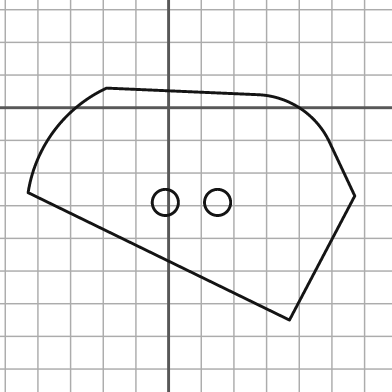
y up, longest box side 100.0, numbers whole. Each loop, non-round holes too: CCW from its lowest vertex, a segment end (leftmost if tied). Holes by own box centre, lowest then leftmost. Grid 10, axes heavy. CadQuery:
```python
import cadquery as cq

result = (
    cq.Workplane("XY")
    .moveTo(37.0, -65.0)
    .lineTo(57.0, -27.0)
    .lineTo(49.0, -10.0)
    .threePointArc((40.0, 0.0), (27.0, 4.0))
    .lineTo(-19.0, 6.0)
    .threePointArc((-35.0, -7.0), (-43.0, -26.0))
    .close()
    .moveTo(-1.0, -29.0)
    .circle(4.0)
    .moveTo(15.0, -29.0)
    .circle(4.0)
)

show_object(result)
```